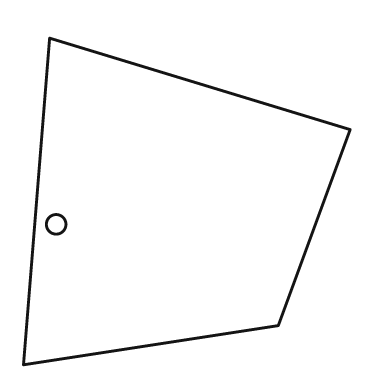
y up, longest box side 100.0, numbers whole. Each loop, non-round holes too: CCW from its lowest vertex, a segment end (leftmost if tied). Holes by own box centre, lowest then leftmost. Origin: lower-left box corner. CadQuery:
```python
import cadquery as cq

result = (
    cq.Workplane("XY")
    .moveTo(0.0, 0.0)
    .lineTo(78.0, 12.0)
    .lineTo(100.0, 72.0)
    .lineTo(8.0, 100.0)
    .close()
    .moveTo(10.0, 43.0)
    .circle(3.0)
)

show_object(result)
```